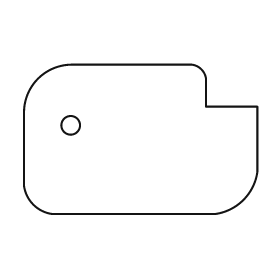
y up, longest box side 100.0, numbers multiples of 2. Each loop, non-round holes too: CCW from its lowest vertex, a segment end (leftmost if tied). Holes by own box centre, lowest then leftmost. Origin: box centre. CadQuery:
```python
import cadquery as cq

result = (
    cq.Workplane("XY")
    .moveTo(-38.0, -32.0)
    .lineTo(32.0, -32.0)
    .threePointArc((44.0, -26.0), (50.0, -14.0))
    .lineTo(50.0, 14.0)
    .lineTo(28.0, 14.0)
    .lineTo(28.0, 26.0)
    .threePointArc((26.0, 30.0), (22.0, 32.0))
    .lineTo(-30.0, 32.0)
    .threePointArc((-44.0, 26.0), (-50.0, 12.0))
    .lineTo(-50.0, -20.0)
    .threePointArc((-46.0, -28.0), (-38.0, -32.0))
    .close()
    .moveTo(-30.0, 6.0)
    .circle(4.0)
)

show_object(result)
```